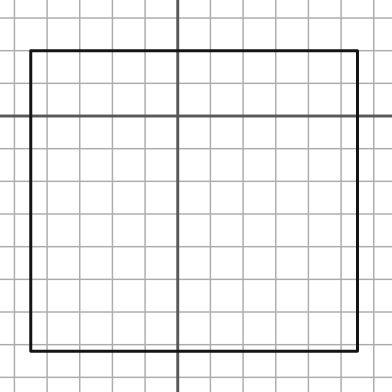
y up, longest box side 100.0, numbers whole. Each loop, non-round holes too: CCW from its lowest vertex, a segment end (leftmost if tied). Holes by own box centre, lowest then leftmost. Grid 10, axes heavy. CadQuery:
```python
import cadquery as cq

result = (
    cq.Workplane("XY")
    .moveTo(-45.0, -72.0)
    .lineTo(55.0, -72.0)
    .lineTo(55.0, 20.0)
    .lineTo(-45.0, 20.0)
    .close()
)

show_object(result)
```